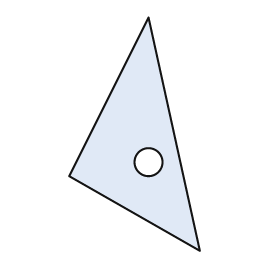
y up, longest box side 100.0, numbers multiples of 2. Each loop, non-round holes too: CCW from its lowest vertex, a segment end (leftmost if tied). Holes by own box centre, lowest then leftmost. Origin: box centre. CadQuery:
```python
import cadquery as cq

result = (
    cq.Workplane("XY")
    .moveTo(28.0, -50.0)
    .lineTo(6.0, 50.0)
    .lineTo(-28.0, -18.0)
    .close()
    .moveTo(6.0, -12.0)
    .circle(6.0)
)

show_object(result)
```